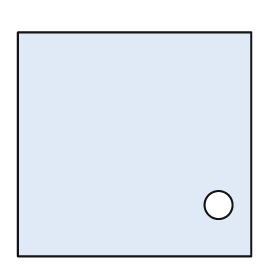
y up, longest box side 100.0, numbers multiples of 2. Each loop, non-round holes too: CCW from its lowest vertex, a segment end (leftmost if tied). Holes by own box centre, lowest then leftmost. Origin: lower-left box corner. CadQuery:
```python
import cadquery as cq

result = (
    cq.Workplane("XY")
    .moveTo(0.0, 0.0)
    .lineTo(100.0, 0.0)
    .lineTo(100.0, 96.0)
    .lineTo(0.0, 96.0)
    .close()
    .moveTo(86.0, 22.0)
    .circle(6.0)
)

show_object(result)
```